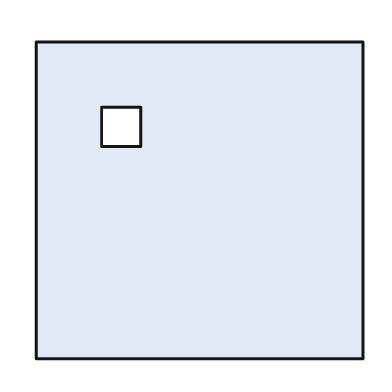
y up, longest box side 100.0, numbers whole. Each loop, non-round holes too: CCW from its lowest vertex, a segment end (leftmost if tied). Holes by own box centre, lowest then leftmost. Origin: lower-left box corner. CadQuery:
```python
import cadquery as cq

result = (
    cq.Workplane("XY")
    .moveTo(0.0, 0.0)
    .lineTo(100.0, 0.0)
    .lineTo(100.0, 97.0)
    .lineTo(0.0, 97.0)
    .close()
    .moveTo(20.0, 65.0)
    .lineTo(32.0, 65.0)
    .lineTo(32.0, 77.0)
    .lineTo(20.0, 77.0)
    .close()
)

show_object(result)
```